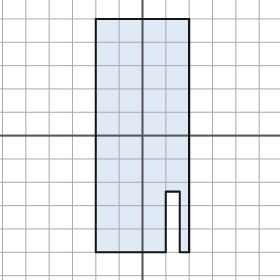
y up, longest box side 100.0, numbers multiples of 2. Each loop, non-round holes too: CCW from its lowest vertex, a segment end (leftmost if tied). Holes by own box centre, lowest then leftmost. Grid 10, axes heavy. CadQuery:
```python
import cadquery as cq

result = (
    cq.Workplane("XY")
    .moveTo(-20.0, -50.0)
    .lineTo(10.0, -50.0)
    .lineTo(10.0, -24.0)
    .lineTo(16.0, -24.0)
    .lineTo(16.0, -50.0)
    .lineTo(20.0, -50.0)
    .lineTo(20.0, 50.0)
    .lineTo(-20.0, 50.0)
    .close()
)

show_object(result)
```